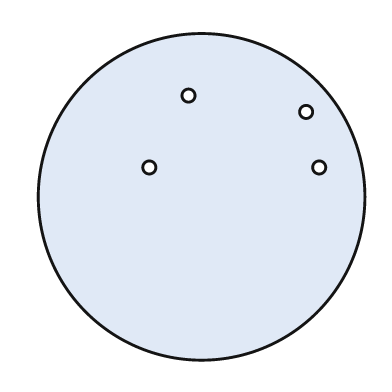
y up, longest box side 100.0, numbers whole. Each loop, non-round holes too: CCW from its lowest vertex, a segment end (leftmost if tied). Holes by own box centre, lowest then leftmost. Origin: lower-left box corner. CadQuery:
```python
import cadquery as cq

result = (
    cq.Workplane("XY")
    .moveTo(50.0, 50.0)
    .circle(50.0)
    .moveTo(34.0, 59.0)
    .circle(2.0)
    .moveTo(86.0, 59.0)
    .circle(2.0)
    .moveTo(82.0, 76.0)
    .circle(2.0)
    .moveTo(46.0, 81.0)
    .circle(2.0)
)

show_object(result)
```